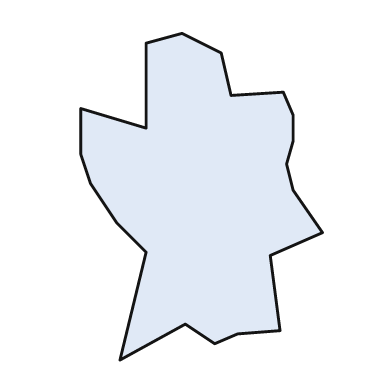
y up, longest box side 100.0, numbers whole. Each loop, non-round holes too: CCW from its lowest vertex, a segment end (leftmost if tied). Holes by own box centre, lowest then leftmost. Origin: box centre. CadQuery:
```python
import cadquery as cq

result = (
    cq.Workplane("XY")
    .moveTo(-25.0, -50.0)
    .lineTo(-5.0, -39.0)
    .lineTo(4.0, -45.0)
    .lineTo(11.0, -42.0)
    .lineTo(24.0, -41.0)
    .lineTo(21.0, -18.0)
    .lineTo(37.0, -11.0)
    .lineTo(28.0, 2.0)
    .lineTo(26.0, 10.0)
    .lineTo(28.0, 17.0)
    .lineTo(28.0, 25.0)
    .lineTo(25.0, 32.0)
    .lineTo(9.0, 31.0)
    .lineTo(6.0, 44.0)
    .lineTo(-6.0, 50.0)
    .lineTo(-17.0, 47.0)
    .lineTo(-17.0, 21.0)
    .lineTo(-37.0, 27.0)
    .lineTo(-37.0, 13.0)
    .lineTo(-34.0, 4.0)
    .lineTo(-26.0, -8.0)
    .lineTo(-17.0, -17.0)
    .close()
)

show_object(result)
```